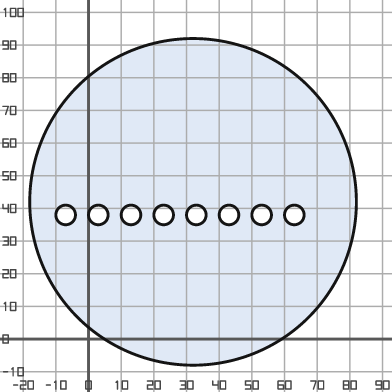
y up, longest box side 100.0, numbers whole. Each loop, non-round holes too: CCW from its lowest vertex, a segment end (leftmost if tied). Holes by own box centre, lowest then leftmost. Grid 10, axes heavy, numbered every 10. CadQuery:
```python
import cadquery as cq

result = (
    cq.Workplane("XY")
    .moveTo(32.0, 42.0)
    .circle(50.0)
    .moveTo(-7.0, 38.0)
    .circle(3.0)
    .moveTo(3.0, 38.0)
    .circle(3.0)
    .moveTo(13.0, 38.0)
    .circle(3.0)
    .moveTo(23.0, 38.0)
    .circle(3.0)
    .moveTo(33.0, 38.0)
    .circle(3.0)
    .moveTo(43.0, 38.0)
    .circle(3.0)
    .moveTo(53.0, 38.0)
    .circle(3.0)
    .moveTo(63.0, 38.0)
    .circle(3.0)
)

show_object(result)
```